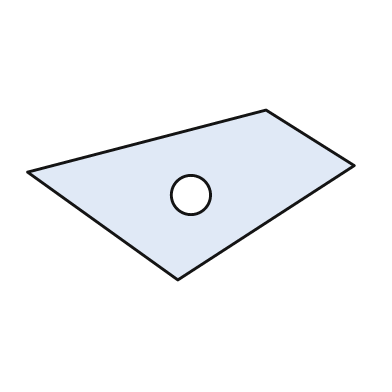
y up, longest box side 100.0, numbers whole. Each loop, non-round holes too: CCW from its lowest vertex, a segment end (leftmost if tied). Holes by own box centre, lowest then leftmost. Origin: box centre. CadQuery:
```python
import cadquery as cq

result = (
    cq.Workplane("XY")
    .moveTo(-4.0, -26.0)
    .lineTo(50.0, 9.0)
    .lineTo(23.0, 26.0)
    .lineTo(-50.0, 7.0)
    .close()
    .moveTo(0.0, 0.0)
    .circle(6.0)
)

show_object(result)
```